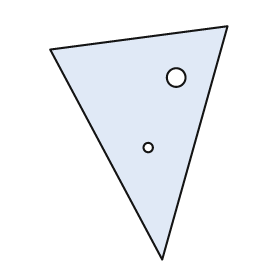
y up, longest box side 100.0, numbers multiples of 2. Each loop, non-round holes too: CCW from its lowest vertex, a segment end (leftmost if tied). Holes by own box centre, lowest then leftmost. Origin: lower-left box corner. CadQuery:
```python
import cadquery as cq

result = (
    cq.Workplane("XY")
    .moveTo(48.0, 0.0)
    .lineTo(76.0, 100.0)
    .lineTo(0.0, 90.0)
    .close()
    .moveTo(42.0, 48.0)
    .circle(2.0)
    .moveTo(54.0, 78.0)
    .circle(4.0)
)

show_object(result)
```